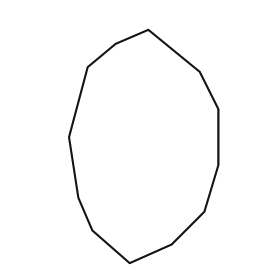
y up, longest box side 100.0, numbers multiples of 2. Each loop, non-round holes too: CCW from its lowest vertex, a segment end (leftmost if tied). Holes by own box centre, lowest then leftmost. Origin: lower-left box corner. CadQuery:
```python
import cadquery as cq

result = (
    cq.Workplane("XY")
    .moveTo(26.0, 0.0)
    .lineTo(44.0, 8.0)
    .lineTo(58.0, 22.0)
    .lineTo(64.0, 42.0)
    .lineTo(64.0, 66.0)
    .lineTo(56.0, 82.0)
    .lineTo(34.0, 100.0)
    .lineTo(20.0, 94.0)
    .lineTo(8.0, 84.0)
    .lineTo(0.0, 54.0)
    .lineTo(4.0, 28.0)
    .lineTo(10.0, 14.0)
    .close()
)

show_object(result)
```